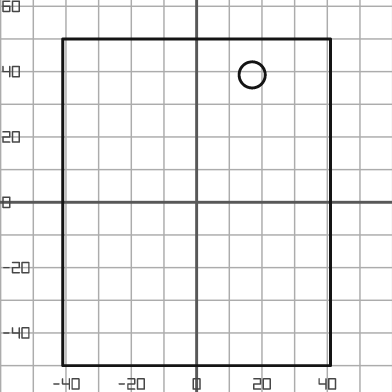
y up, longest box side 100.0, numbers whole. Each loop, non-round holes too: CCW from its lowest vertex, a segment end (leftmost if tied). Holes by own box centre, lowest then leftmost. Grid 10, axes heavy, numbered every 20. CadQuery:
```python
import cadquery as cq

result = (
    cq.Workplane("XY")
    .moveTo(-41.0, -50.0)
    .lineTo(41.0, -50.0)
    .lineTo(41.0, 50.0)
    .lineTo(-41.0, 50.0)
    .close()
    .moveTo(17.0, 39.0)
    .circle(4.0)
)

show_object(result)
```